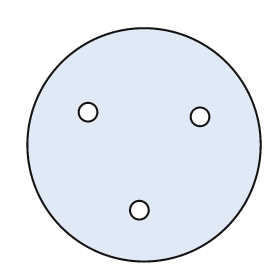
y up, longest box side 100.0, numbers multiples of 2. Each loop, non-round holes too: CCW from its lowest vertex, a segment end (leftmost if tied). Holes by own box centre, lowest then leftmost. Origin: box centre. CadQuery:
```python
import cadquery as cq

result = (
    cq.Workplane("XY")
    .moveTo(0.0, 0.0)
    .circle(50.0)
    .moveTo(-2.0, -28.0)
    .circle(4.0)
    .moveTo(24.0, 12.0)
    .circle(4.0)
    .moveTo(-24.0, 14.0)
    .circle(4.0)
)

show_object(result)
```